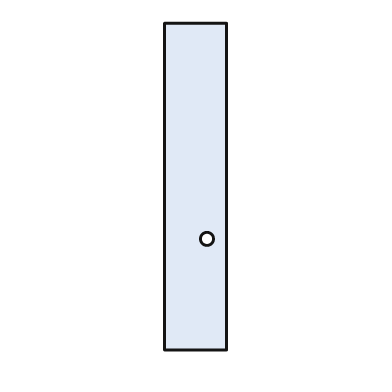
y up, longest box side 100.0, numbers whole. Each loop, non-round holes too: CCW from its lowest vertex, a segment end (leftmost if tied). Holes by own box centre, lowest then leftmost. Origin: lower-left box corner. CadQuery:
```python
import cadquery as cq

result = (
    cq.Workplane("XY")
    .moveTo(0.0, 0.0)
    .lineTo(19.0, 0.0)
    .lineTo(19.0, 100.0)
    .lineTo(0.0, 100.0)
    .close()
    .moveTo(13.0, 34.0)
    .circle(2.0)
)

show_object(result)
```